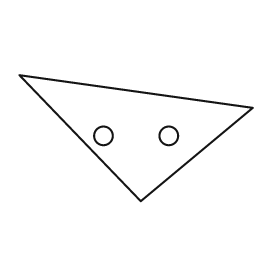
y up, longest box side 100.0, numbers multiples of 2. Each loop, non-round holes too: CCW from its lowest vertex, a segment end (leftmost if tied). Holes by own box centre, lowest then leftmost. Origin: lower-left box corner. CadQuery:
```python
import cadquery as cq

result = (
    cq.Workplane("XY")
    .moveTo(52.0, 0.0)
    .lineTo(100.0, 40.0)
    .lineTo(0.0, 54.0)
    .close()
    .moveTo(36.0, 28.0)
    .circle(4.0)
    .moveTo(64.0, 28.0)
    .circle(4.0)
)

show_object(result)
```